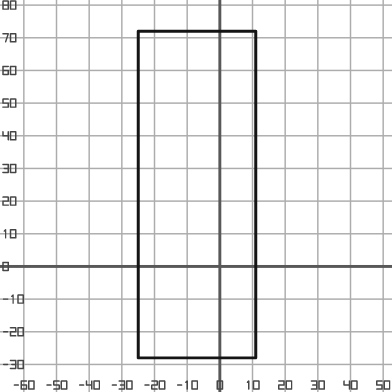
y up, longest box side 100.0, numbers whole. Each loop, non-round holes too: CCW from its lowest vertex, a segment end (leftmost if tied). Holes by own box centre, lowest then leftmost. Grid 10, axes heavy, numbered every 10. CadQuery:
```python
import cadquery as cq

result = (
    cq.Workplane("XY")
    .moveTo(-25.0, -28.0)
    .lineTo(11.0, -28.0)
    .lineTo(11.0, 72.0)
    .lineTo(-25.0, 72.0)
    .close()
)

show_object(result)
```